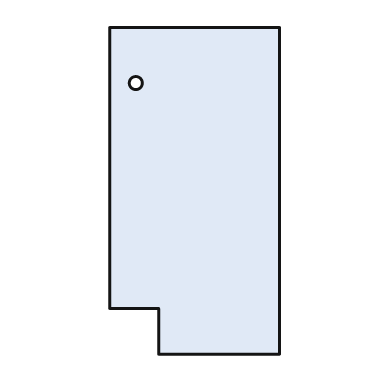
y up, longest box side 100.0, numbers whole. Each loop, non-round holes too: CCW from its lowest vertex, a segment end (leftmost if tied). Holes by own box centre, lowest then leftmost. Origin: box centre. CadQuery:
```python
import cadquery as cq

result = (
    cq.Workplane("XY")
    .moveTo(-11.0, -50.0)
    .lineTo(26.0, -50.0)
    .lineTo(26.0, 50.0)
    .lineTo(-26.0, 50.0)
    .lineTo(-26.0, -36.0)
    .lineTo(-11.0, -36.0)
    .close()
    .moveTo(-18.0, 33.0)
    .circle(2.0)
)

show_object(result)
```